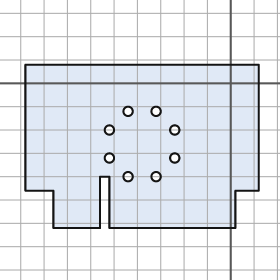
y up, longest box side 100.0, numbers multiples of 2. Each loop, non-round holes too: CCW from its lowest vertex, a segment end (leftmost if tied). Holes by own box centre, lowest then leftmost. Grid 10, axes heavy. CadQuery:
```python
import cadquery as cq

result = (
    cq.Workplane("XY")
    .moveTo(-76.0, -62.0)
    .lineTo(-56.0, -62.0)
    .lineTo(-56.0, -40.0)
    .lineTo(-52.0, -40.0)
    .lineTo(-52.0, -62.0)
    .lineTo(2.0, -62.0)
    .lineTo(2.0, -46.0)
    .lineTo(12.0, -46.0)
    .lineTo(12.0, 8.0)
    .lineTo(-88.0, 8.0)
    .lineTo(-88.0, -46.0)
    .lineTo(-76.0, -46.0)
    .close()
    .moveTo(-44.0, -40.0)
    .circle(2.0)
    .moveTo(-32.0, -40.0)
    .circle(2.0)
    .moveTo(-52.0, -32.0)
    .circle(2.0)
    .moveTo(-24.0, -32.0)
    .circle(2.0)
    .moveTo(-52.0, -20.0)
    .circle(2.0)
    .moveTo(-24.0, -20.0)
    .circle(2.0)
    .moveTo(-44.0, -12.0)
    .circle(2.0)
    .moveTo(-32.0, -12.0)
    .circle(2.0)
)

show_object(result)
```